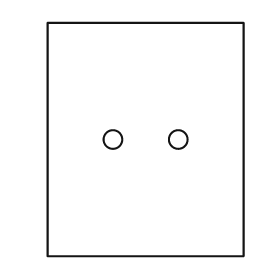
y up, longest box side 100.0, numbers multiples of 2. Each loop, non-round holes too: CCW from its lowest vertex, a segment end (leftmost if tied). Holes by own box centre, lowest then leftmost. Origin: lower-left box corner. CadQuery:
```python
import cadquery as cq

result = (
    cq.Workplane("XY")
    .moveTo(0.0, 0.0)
    .lineTo(84.0, 0.0)
    .lineTo(84.0, 100.0)
    .lineTo(0.0, 100.0)
    .close()
    .moveTo(28.0, 50.0)
    .circle(4.0)
    .moveTo(56.0, 50.0)
    .circle(4.0)
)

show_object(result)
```